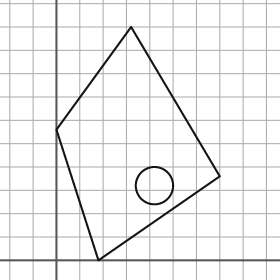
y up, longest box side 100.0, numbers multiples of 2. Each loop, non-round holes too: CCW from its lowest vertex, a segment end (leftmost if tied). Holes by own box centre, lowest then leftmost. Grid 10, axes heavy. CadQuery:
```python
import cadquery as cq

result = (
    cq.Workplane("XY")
    .moveTo(18.0, 0.0)
    .lineTo(70.0, 36.0)
    .lineTo(32.0, 100.0)
    .lineTo(0.0, 56.0)
    .close()
    .moveTo(42.0, 32.0)
    .circle(8.0)
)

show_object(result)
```